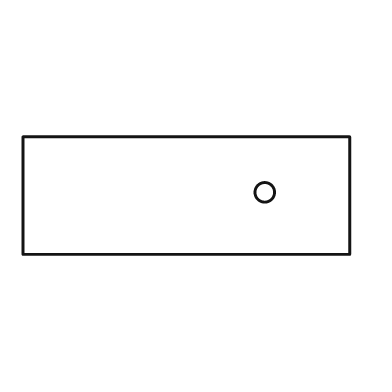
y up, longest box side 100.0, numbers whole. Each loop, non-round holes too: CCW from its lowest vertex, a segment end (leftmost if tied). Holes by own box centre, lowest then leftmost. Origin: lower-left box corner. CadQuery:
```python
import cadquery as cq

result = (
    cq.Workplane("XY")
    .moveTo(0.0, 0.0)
    .lineTo(100.0, 0.0)
    .lineTo(100.0, 36.0)
    .lineTo(0.0, 36.0)
    .close()
    .moveTo(74.0, 19.0)
    .circle(3.0)
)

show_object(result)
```